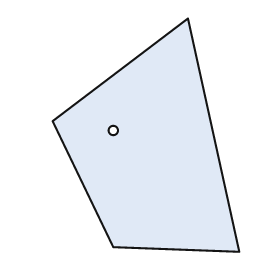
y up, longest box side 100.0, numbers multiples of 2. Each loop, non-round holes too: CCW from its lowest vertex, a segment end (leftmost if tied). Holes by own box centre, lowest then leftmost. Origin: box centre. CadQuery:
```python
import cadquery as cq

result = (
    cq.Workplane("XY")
    .moveTo(40.0, -50.0)
    .lineTo(18.0, 50.0)
    .lineTo(-40.0, 6.0)
    .lineTo(-14.0, -48.0)
    .close()
    .moveTo(-14.0, 2.0)
    .circle(2.0)
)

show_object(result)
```